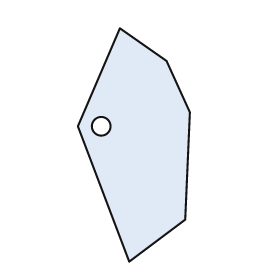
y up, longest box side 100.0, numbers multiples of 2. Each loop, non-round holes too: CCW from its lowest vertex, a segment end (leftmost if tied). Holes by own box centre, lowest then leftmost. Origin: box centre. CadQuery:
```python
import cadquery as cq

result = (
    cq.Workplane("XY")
    .moveTo(-2.0, -50.0)
    .lineTo(22.0, -32.0)
    .lineTo(24.0, 14.0)
    .lineTo(14.0, 36.0)
    .lineTo(-6.0, 50.0)
    .lineTo(-24.0, 8.0)
    .close()
    .moveTo(-14.0, 8.0)
    .circle(4.0)
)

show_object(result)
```